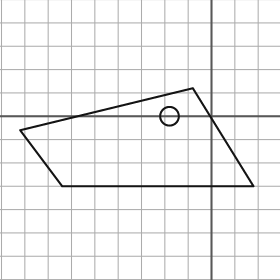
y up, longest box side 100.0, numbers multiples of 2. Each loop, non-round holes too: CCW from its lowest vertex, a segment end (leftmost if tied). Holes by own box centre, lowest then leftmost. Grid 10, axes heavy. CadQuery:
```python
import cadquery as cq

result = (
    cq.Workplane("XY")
    .moveTo(-64.0, -30.0)
    .lineTo(18.0, -30.0)
    .lineTo(-8.0, 12.0)
    .lineTo(-82.0, -6.0)
    .close()
    .moveTo(-18.0, 0.0)
    .circle(4.0)
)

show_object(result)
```